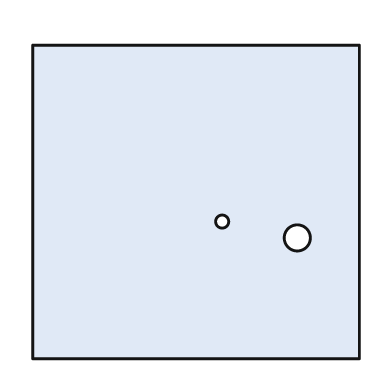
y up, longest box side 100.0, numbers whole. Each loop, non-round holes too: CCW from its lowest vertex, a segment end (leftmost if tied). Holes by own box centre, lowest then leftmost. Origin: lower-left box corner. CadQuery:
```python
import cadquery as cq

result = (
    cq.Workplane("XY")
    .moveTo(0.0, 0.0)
    .lineTo(100.0, 0.0)
    .lineTo(100.0, 96.0)
    .lineTo(0.0, 96.0)
    .close()
    .moveTo(81.0, 37.0)
    .circle(4.0)
    .moveTo(58.0, 42.0)
    .circle(2.0)
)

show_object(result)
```